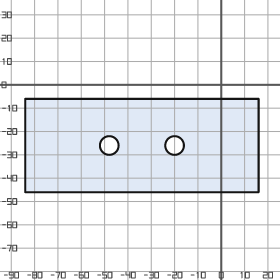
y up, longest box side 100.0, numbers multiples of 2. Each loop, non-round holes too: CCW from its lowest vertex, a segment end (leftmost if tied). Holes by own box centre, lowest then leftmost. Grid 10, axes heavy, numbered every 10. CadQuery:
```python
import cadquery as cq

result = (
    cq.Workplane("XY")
    .moveTo(-84.0, -46.0)
    .lineTo(16.0, -46.0)
    .lineTo(16.0, -6.0)
    .lineTo(-84.0, -6.0)
    .close()
    .moveTo(-48.0, -26.0)
    .circle(4.0)
    .moveTo(-20.0, -26.0)
    .circle(4.0)
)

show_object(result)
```